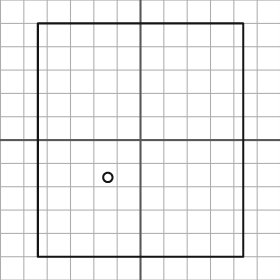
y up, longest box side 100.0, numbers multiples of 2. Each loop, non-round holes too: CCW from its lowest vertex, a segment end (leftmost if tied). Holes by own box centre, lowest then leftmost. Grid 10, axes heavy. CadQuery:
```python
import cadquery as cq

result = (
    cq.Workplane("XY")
    .moveTo(-44.0, -50.0)
    .lineTo(44.0, -50.0)
    .lineTo(44.0, 50.0)
    .lineTo(-44.0, 50.0)
    .close()
    .moveTo(-14.0, -16.0)
    .circle(2.0)
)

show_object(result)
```